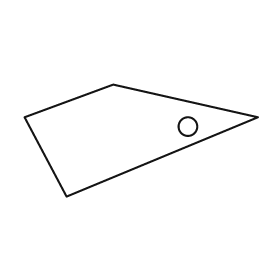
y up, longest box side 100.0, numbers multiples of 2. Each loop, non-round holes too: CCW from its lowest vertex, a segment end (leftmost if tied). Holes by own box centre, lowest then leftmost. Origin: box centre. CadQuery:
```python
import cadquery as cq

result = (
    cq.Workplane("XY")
    .moveTo(-32.0, -24.0)
    .lineTo(50.0, 10.0)
    .lineTo(-12.0, 24.0)
    .lineTo(-50.0, 10.0)
    .close()
    .moveTo(20.0, 6.0)
    .circle(4.0)
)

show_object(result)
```